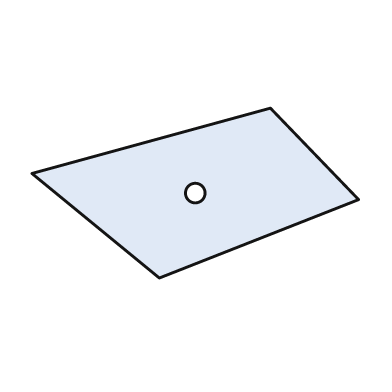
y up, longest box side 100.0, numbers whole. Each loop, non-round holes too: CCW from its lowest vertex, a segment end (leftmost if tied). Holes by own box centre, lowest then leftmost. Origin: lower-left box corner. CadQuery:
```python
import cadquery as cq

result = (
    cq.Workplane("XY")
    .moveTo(39.0, 0.0)
    .lineTo(100.0, 24.0)
    .lineTo(73.0, 52.0)
    .lineTo(0.0, 32.0)
    .close()
    .moveTo(50.0, 26.0)
    .circle(3.0)
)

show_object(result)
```